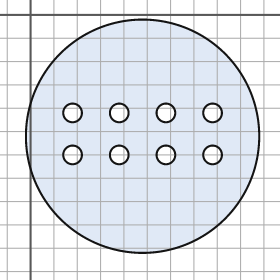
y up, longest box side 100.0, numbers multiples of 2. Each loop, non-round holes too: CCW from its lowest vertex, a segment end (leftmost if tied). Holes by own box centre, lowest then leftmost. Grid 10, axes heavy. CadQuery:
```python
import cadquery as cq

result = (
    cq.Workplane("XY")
    .moveTo(48.0, -52.0)
    .circle(50.0)
    .moveTo(18.0, -60.0)
    .circle(4.0)
    .moveTo(38.0, -60.0)
    .circle(4.0)
    .moveTo(58.0, -60.0)
    .circle(4.0)
    .moveTo(78.0, -60.0)
    .circle(4.0)
    .moveTo(18.0, -42.0)
    .circle(4.0)
    .moveTo(38.0, -42.0)
    .circle(4.0)
    .moveTo(58.0, -42.0)
    .circle(4.0)
    .moveTo(78.0, -42.0)
    .circle(4.0)
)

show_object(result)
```